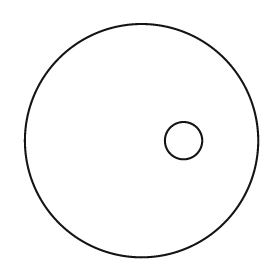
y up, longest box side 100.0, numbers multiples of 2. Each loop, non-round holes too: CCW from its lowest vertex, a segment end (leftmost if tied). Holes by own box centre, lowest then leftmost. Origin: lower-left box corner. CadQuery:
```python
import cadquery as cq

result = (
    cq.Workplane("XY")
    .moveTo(50.0, 50.0)
    .circle(50.0)
    .moveTo(68.0, 50.0)
    .circle(8.0)
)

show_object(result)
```